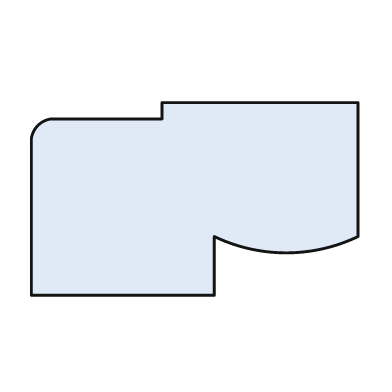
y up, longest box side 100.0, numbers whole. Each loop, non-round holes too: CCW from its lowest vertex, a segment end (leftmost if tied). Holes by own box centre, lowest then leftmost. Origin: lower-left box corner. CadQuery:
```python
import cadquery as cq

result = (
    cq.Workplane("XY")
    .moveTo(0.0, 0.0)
    .lineTo(56.0, 0.0)
    .lineTo(56.0, 18.0)
    .threePointArc((78.0, 13.0), (100.0, 18.0))
    .lineTo(100.0, 59.0)
    .lineTo(40.0, 59.0)
    .lineTo(40.0, 54.0)
    .lineTo(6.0, 54.0)
    .threePointArc((2.0, 52.0), (0.0, 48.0))
    .close()
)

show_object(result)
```